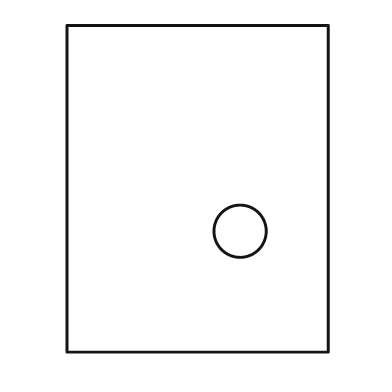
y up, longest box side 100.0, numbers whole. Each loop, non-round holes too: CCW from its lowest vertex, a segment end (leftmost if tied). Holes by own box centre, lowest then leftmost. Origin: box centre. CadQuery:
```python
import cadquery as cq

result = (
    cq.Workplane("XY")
    .moveTo(-40.0, -50.0)
    .lineTo(40.0, -50.0)
    .lineTo(40.0, 50.0)
    .lineTo(-40.0, 50.0)
    .close()
    .moveTo(13.0, -13.0)
    .circle(8.0)
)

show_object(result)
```